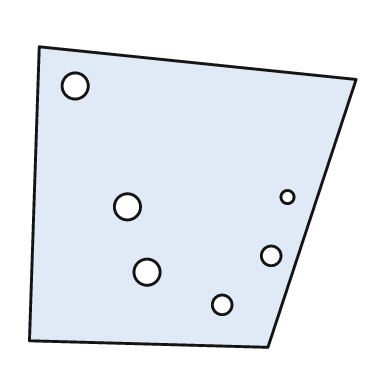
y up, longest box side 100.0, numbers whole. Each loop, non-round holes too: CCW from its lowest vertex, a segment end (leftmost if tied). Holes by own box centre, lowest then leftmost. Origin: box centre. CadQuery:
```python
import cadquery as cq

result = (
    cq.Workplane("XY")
    .moveTo(23.0, -46.0)
    .lineTo(50.0, 36.0)
    .lineTo(-47.0, 46.0)
    .lineTo(-50.0, -44.0)
    .close()
    .moveTo(9.0, -33.0)
    .circle(3.0)
    .moveTo(-14.0, -23.0)
    .circle(4.0)
    .moveTo(24.0, -18.0)
    .circle(3.0)
    .moveTo(-20.0, -3.0)
    .circle(4.0)
    .moveTo(29.0, 0.0)
    .circle(2.0)
    .moveTo(-36.0, 34.0)
    .circle(4.0)
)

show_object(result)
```